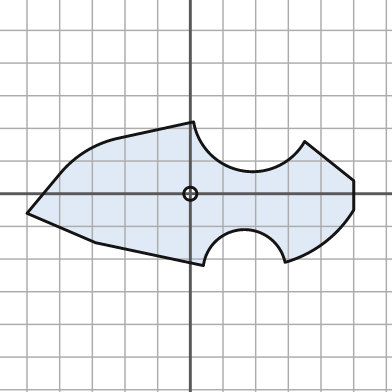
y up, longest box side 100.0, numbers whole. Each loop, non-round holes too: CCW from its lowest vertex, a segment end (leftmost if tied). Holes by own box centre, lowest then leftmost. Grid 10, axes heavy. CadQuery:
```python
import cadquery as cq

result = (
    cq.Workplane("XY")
    .moveTo(4.0, -22.0)
    .threePointArc((16.0, -11.0), (29.0, -21.0))
    .threePointArc((41.0, -15.0), (50.0, -5.0))
    .lineTo(50.0, 4.0)
    .lineTo(35.0, 16.0)
    .threePointArc((16.0, 7.0), (1.0, 22.0))
    .lineTo(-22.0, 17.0)
    .threePointArc((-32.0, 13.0), (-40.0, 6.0))
    .lineTo(-50.0, -6.0)
    .lineTo(-29.0, -15.0)
    .close()
    .moveTo(0.0, 0.0)
    .circle(2.0)
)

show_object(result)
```